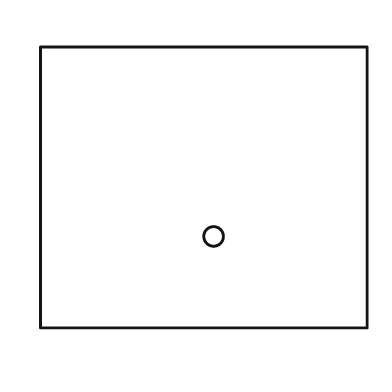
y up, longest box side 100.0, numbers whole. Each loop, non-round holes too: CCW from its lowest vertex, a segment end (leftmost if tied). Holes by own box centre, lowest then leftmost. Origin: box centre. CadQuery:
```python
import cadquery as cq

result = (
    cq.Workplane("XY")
    .moveTo(-50.0, -43.0)
    .lineTo(50.0, -43.0)
    .lineTo(50.0, 43.0)
    .lineTo(-50.0, 43.0)
    .close()
    .moveTo(3.0, -15.0)
    .circle(3.0)
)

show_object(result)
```